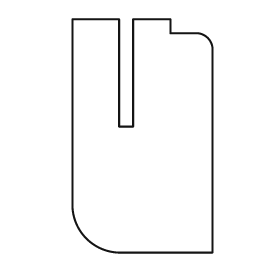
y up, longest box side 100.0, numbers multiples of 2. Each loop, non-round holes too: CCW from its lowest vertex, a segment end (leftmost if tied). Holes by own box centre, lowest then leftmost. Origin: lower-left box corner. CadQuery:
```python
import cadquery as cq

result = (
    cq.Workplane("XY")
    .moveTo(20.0, 0.0)
    .lineTo(60.0, 0.0)
    .lineTo(60.0, 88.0)
    .threePointArc((58.0, 92.0), (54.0, 94.0))
    .lineTo(42.0, 94.0)
    .lineTo(42.0, 100.0)
    .lineTo(26.0, 100.0)
    .lineTo(26.0, 54.0)
    .lineTo(20.0, 54.0)
    .lineTo(20.0, 100.0)
    .lineTo(0.0, 100.0)
    .lineTo(0.0, 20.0)
    .threePointArc((6.0, 6.0), (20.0, 0.0))
    .close()
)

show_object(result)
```